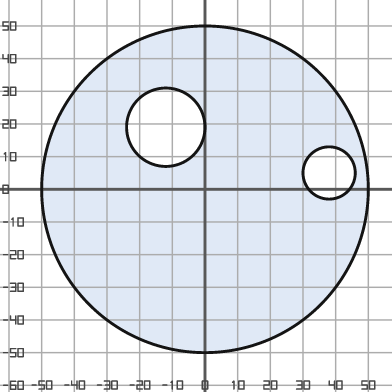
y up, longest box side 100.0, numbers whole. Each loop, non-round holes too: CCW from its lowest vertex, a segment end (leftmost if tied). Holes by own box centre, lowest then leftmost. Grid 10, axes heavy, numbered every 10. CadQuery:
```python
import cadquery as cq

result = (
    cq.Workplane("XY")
    .moveTo(0.0, 0.0)
    .circle(50.0)
    .moveTo(38.0, 5.0)
    .circle(8.0)
    .moveTo(-12.0, 19.0)
    .circle(12.0)
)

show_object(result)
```